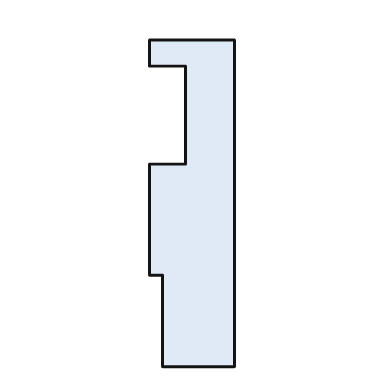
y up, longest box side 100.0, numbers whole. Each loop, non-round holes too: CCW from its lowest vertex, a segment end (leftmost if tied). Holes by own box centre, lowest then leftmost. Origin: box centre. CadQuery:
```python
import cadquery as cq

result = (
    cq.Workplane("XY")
    .moveTo(-9.0, -50.0)
    .lineTo(13.0, -50.0)
    .lineTo(13.0, 50.0)
    .lineTo(-13.0, 50.0)
    .lineTo(-13.0, 42.0)
    .lineTo(-2.0, 42.0)
    .lineTo(-2.0, 12.0)
    .lineTo(-13.0, 12.0)
    .lineTo(-13.0, -22.0)
    .lineTo(-9.0, -22.0)
    .close()
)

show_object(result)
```